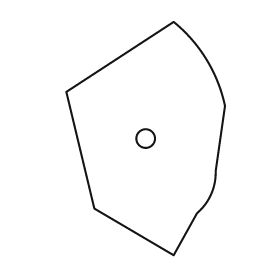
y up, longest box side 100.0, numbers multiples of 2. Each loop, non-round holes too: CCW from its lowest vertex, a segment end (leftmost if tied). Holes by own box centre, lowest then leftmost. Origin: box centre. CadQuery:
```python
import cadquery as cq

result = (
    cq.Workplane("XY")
    .moveTo(12.0, -50.0)
    .lineTo(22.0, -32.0)
    .threePointArc((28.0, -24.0), (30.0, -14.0))
    .lineTo(34.0, 14.0)
    .threePointArc((26.0, 34.0), (12.0, 50.0))
    .lineTo(-34.0, 20.0)
    .lineTo(-22.0, -30.0)
    .close()
    .moveTo(0.0, 0.0)
    .circle(4.0)
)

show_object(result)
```